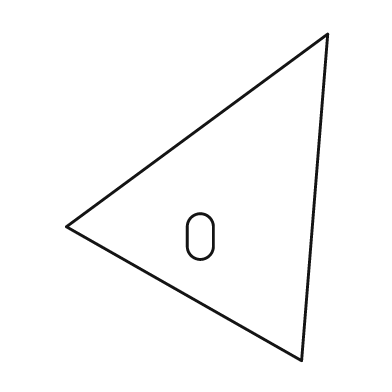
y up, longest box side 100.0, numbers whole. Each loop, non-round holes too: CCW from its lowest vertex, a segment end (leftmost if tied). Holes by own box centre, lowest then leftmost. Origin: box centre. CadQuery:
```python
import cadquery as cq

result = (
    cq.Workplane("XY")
    .moveTo(32.0, -50.0)
    .lineTo(40.0, 50.0)
    .lineTo(-40.0, -9.0)
    .close()
    .moveTo(-3.0, -15.0)
    .threePointArc((1.0, -19.0), (5.0, -15.0))
    .lineTo(5.0, -9.0)
    .threePointArc((1.0, -5.0), (-3.0, -9.0))
    .close()
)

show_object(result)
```